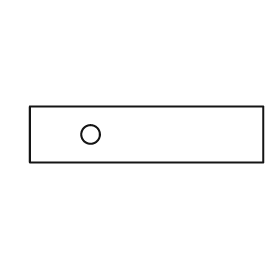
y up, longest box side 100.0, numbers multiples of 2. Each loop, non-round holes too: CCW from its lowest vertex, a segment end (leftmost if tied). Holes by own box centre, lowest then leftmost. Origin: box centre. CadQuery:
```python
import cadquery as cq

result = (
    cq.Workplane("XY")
    .moveTo(-50.0, -12.0)
    .lineTo(50.0, -12.0)
    .lineTo(50.0, 12.0)
    .lineTo(-50.0, 12.0)
    .close()
    .moveTo(-24.0, 0.0)
    .circle(4.0)
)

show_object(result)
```